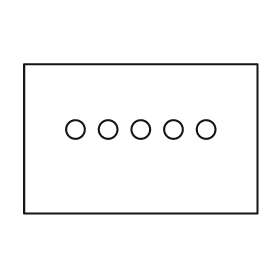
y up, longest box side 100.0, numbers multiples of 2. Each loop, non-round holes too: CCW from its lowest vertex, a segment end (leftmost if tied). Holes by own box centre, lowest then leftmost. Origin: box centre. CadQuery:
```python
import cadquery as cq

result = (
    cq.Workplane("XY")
    .moveTo(-50.0, -32.0)
    .lineTo(50.0, -32.0)
    .lineTo(50.0, 32.0)
    .lineTo(-50.0, 32.0)
    .close()
    .moveTo(-28.0, 4.0)
    .circle(4.0)
    .moveTo(-14.0, 4.0)
    .circle(4.0)
    .moveTo(0.0, 4.0)
    .circle(4.0)
    .moveTo(14.0, 4.0)
    .circle(4.0)
    .moveTo(28.0, 4.0)
    .circle(4.0)
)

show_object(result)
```